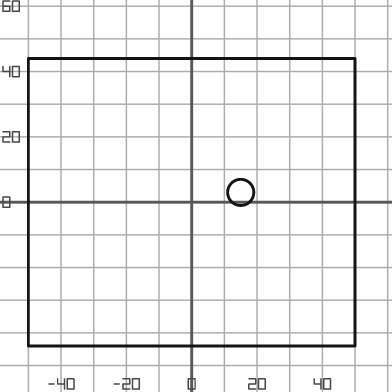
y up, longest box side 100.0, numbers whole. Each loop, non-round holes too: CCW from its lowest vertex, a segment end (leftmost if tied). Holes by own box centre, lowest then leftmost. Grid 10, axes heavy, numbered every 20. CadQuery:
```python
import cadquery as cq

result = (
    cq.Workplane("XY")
    .moveTo(-50.0, -44.0)
    .lineTo(50.0, -44.0)
    .lineTo(50.0, 44.0)
    .lineTo(-50.0, 44.0)
    .close()
    .moveTo(15.0, 3.0)
    .circle(4.0)
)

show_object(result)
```